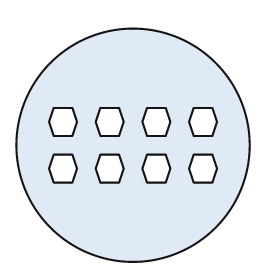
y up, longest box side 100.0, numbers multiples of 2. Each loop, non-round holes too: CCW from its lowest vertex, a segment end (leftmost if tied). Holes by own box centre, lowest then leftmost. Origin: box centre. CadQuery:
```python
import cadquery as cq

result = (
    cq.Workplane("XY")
    .moveTo(0.0, 0.0)
    .circle(50.0)
    .moveTo(-34.0, -16.0)
    .lineTo(-26.0, -16.0)
    .lineTo(-24.0, -10.0)
    .lineTo(-26.0, -4.0)
    .lineTo(-34.0, -4.0)
    .lineTo(-36.0, -10.0)
    .close()
    .moveTo(-14.0, -16.0)
    .lineTo(-6.0, -16.0)
    .lineTo(-4.0, -10.0)
    .lineTo(-6.0, -4.0)
    .lineTo(-14.0, -4.0)
    .lineTo(-16.0, -10.0)
    .close()
    .moveTo(6.0, -16.0)
    .lineTo(14.0, -16.0)
    .lineTo(16.0, -10.0)
    .lineTo(14.0, -4.0)
    .lineTo(6.0, -4.0)
    .lineTo(4.0, -10.0)
    .close()
    .moveTo(26.0, -16.0)
    .lineTo(34.0, -16.0)
    .lineTo(36.0, -10.0)
    .lineTo(34.0, -4.0)
    .lineTo(26.0, -4.0)
    .lineTo(24.0, -10.0)
    .close()
    .moveTo(-34.0, 4.0)
    .lineTo(-26.0, 4.0)
    .lineTo(-24.0, 10.0)
    .lineTo(-26.0, 16.0)
    .lineTo(-34.0, 16.0)
    .lineTo(-36.0, 10.0)
    .close()
    .moveTo(-14.0, 4.0)
    .lineTo(-6.0, 4.0)
    .lineTo(-4.0, 10.0)
    .lineTo(-6.0, 16.0)
    .lineTo(-14.0, 16.0)
    .lineTo(-16.0, 10.0)
    .close()
    .moveTo(6.0, 4.0)
    .lineTo(14.0, 4.0)
    .lineTo(16.0, 10.0)
    .lineTo(14.0, 16.0)
    .lineTo(6.0, 16.0)
    .lineTo(4.0, 10.0)
    .close()
    .moveTo(26.0, 4.0)
    .lineTo(34.0, 4.0)
    .lineTo(36.0, 10.0)
    .lineTo(34.0, 16.0)
    .lineTo(26.0, 16.0)
    .lineTo(24.0, 10.0)
    .close()
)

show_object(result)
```